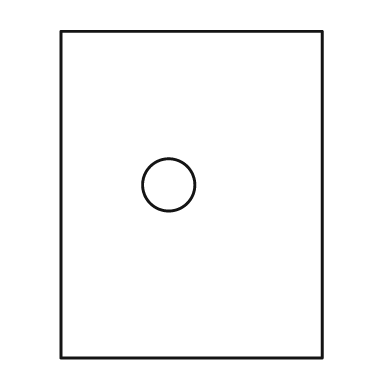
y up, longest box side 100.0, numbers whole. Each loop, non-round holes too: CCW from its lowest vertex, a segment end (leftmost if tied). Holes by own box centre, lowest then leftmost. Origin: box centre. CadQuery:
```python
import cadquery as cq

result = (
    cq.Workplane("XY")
    .moveTo(-40.0, -50.0)
    .lineTo(40.0, -50.0)
    .lineTo(40.0, 50.0)
    .lineTo(-40.0, 50.0)
    .close()
    .moveTo(-7.0, 3.0)
    .circle(8.0)
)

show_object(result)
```